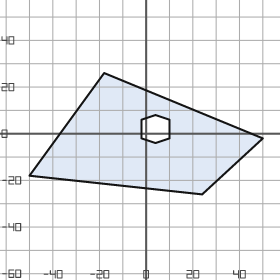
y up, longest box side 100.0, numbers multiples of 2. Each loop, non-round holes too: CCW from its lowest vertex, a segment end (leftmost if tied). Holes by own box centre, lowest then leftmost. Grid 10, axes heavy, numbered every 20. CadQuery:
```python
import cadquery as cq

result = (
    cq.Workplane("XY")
    .moveTo(24.0, -26.0)
    .lineTo(50.0, -2.0)
    .lineTo(-18.0, 26.0)
    .lineTo(-50.0, -18.0)
    .close()
    .moveTo(4.0, -4.0)
    .lineTo(10.0, -2.0)
    .lineTo(10.0, 6.0)
    .lineTo(4.0, 8.0)
    .lineTo(-2.0, 6.0)
    .lineTo(-2.0, -2.0)
    .close()
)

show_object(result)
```